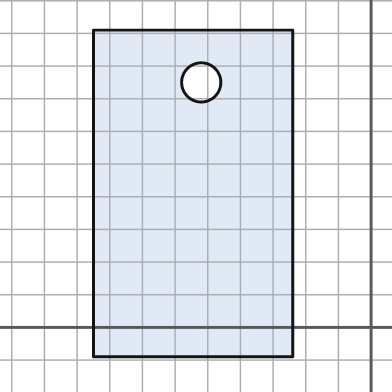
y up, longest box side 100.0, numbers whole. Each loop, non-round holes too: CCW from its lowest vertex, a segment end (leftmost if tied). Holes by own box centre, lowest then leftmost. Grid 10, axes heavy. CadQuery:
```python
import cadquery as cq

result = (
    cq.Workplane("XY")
    .moveTo(-85.0, -9.0)
    .lineTo(-24.0, -9.0)
    .lineTo(-24.0, 91.0)
    .lineTo(-85.0, 91.0)
    .close()
    .moveTo(-52.0, 75.0)
    .circle(6.0)
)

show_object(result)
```